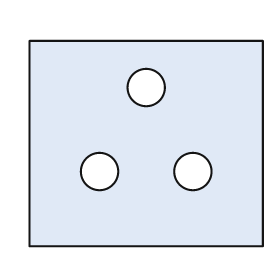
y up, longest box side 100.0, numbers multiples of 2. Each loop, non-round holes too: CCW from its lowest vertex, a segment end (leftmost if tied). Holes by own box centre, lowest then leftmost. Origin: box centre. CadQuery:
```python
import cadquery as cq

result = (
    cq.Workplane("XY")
    .moveTo(-50.0, -44.0)
    .lineTo(50.0, -44.0)
    .lineTo(50.0, 44.0)
    .lineTo(-50.0, 44.0)
    .close()
    .moveTo(-20.0, -12.0)
    .circle(8.0)
    .moveTo(20.0, -12.0)
    .circle(8.0)
    .moveTo(0.0, 24.0)
    .circle(8.0)
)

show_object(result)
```